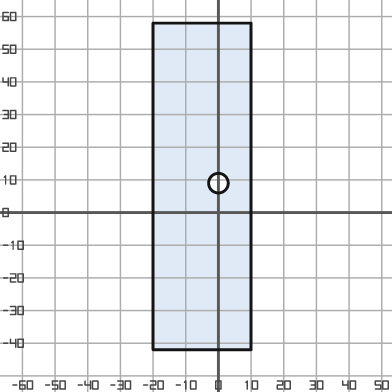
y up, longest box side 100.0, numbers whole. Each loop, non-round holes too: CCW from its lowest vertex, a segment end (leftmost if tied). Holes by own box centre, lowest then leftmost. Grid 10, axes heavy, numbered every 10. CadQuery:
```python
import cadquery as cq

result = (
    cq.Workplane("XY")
    .moveTo(-20.0, -42.0)
    .lineTo(10.0, -42.0)
    .lineTo(10.0, 58.0)
    .lineTo(-20.0, 58.0)
    .close()
    .moveTo(0.0, 9.0)
    .circle(3.0)
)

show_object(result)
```